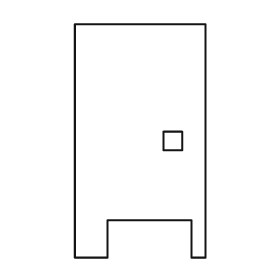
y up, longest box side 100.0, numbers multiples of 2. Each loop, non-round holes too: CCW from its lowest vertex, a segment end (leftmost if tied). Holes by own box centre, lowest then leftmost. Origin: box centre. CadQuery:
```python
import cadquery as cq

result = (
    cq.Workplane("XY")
    .moveTo(-28.0, -50.0)
    .lineTo(-14.0, -50.0)
    .lineTo(-14.0, -34.0)
    .lineTo(22.0, -34.0)
    .lineTo(22.0, -50.0)
    .lineTo(28.0, -50.0)
    .lineTo(28.0, 50.0)
    .lineTo(-28.0, 50.0)
    .close()
    .moveTo(10.0, -4.0)
    .lineTo(18.0, -4.0)
    .lineTo(18.0, 4.0)
    .lineTo(10.0, 4.0)
    .close()
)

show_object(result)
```